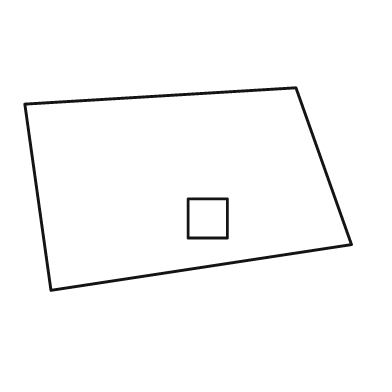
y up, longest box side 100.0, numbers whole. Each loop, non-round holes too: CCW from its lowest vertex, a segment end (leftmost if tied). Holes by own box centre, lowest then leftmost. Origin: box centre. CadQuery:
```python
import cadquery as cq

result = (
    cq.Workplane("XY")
    .moveTo(-42.0, -31.0)
    .lineTo(50.0, -17.0)
    .lineTo(33.0, 31.0)
    .lineTo(-50.0, 26.0)
    .close()
    .moveTo(0.0, -15.0)
    .lineTo(12.0, -15.0)
    .lineTo(12.0, -3.0)
    .lineTo(0.0, -3.0)
    .close()
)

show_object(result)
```